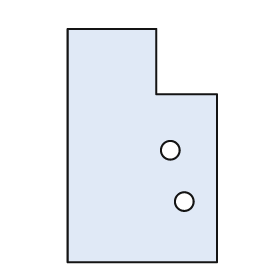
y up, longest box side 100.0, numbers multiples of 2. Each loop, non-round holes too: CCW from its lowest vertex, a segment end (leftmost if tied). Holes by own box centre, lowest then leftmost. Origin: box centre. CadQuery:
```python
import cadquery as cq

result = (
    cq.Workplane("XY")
    .moveTo(-32.0, -50.0)
    .lineTo(32.0, -50.0)
    .lineTo(32.0, 22.0)
    .lineTo(6.0, 22.0)
    .lineTo(6.0, 50.0)
    .lineTo(-32.0, 50.0)
    .close()
    .moveTo(18.0, -24.0)
    .circle(4.0)
    .moveTo(12.0, -2.0)
    .circle(4.0)
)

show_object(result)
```